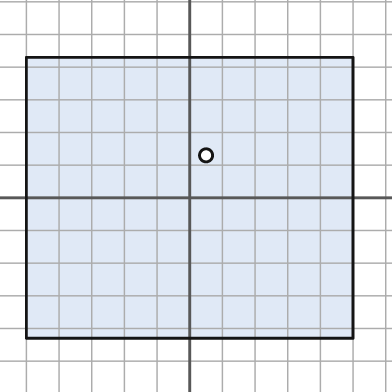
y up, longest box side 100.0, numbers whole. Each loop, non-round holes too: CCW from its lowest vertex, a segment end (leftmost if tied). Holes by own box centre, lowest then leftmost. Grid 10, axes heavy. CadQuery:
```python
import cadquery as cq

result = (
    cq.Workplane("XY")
    .moveTo(-50.0, -43.0)
    .lineTo(50.0, -43.0)
    .lineTo(50.0, 43.0)
    .lineTo(-50.0, 43.0)
    .close()
    .moveTo(5.0, 13.0)
    .circle(2.0)
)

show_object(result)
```